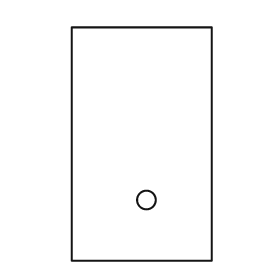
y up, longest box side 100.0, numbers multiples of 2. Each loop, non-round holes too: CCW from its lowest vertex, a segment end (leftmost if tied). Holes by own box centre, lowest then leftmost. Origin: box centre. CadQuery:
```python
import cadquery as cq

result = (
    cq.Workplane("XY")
    .moveTo(-30.0, -50.0)
    .lineTo(30.0, -50.0)
    .lineTo(30.0, 50.0)
    .lineTo(-30.0, 50.0)
    .close()
    .moveTo(2.0, -24.0)
    .circle(4.0)
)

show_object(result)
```